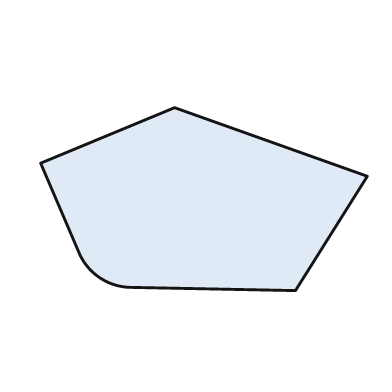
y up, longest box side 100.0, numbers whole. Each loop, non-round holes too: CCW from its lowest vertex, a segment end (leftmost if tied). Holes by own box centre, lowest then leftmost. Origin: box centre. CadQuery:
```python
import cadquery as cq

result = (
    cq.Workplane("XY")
    .moveTo(28.0, -28.0)
    .lineTo(50.0, 7.0)
    .lineTo(-9.0, 28.0)
    .lineTo(-50.0, 11.0)
    .lineTo(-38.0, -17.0)
    .threePointArc((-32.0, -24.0), (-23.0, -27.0))
    .close()
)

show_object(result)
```